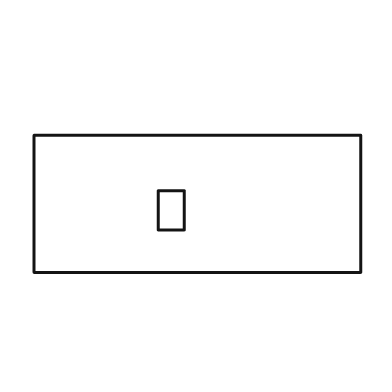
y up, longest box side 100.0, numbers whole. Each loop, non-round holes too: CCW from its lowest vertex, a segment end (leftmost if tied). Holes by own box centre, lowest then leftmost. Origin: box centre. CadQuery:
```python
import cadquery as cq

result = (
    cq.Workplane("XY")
    .moveTo(-50.0, -21.0)
    .lineTo(50.0, -21.0)
    .lineTo(50.0, 21.0)
    .lineTo(-50.0, 21.0)
    .close()
    .moveTo(-12.0, -8.0)
    .lineTo(-4.0, -8.0)
    .lineTo(-4.0, 4.0)
    .lineTo(-12.0, 4.0)
    .close()
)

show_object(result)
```